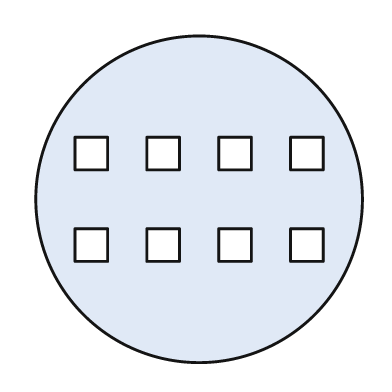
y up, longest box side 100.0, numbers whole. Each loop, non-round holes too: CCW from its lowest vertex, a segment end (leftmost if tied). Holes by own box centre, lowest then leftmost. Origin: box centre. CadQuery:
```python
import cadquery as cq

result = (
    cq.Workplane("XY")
    .moveTo(0.0, 0.0)
    .circle(50.0)
    .moveTo(-38.0, -19.0)
    .lineTo(-28.0, -19.0)
    .lineTo(-28.0, -9.0)
    .lineTo(-38.0, -9.0)
    .close()
    .moveTo(-16.0, -19.0)
    .lineTo(-6.0, -19.0)
    .lineTo(-6.0, -9.0)
    .lineTo(-16.0, -9.0)
    .close()
    .moveTo(6.0, -19.0)
    .lineTo(16.0, -19.0)
    .lineTo(16.0, -9.0)
    .lineTo(6.0, -9.0)
    .close()
    .moveTo(28.0, -19.0)
    .lineTo(38.0, -19.0)
    .lineTo(38.0, -9.0)
    .lineTo(28.0, -9.0)
    .close()
    .moveTo(-38.0, 9.0)
    .lineTo(-28.0, 9.0)
    .lineTo(-28.0, 19.0)
    .lineTo(-38.0, 19.0)
    .close()
    .moveTo(-16.0, 9.0)
    .lineTo(-6.0, 9.0)
    .lineTo(-6.0, 19.0)
    .lineTo(-16.0, 19.0)
    .close()
    .moveTo(6.0, 9.0)
    .lineTo(16.0, 9.0)
    .lineTo(16.0, 19.0)
    .lineTo(6.0, 19.0)
    .close()
    .moveTo(28.0, 9.0)
    .lineTo(38.0, 9.0)
    .lineTo(38.0, 19.0)
    .lineTo(28.0, 19.0)
    .close()
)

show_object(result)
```